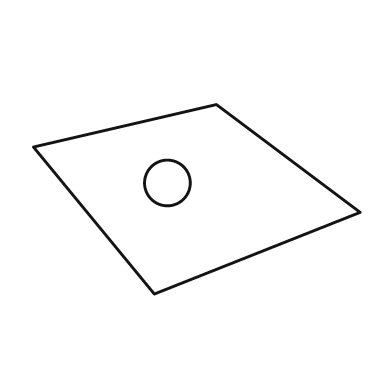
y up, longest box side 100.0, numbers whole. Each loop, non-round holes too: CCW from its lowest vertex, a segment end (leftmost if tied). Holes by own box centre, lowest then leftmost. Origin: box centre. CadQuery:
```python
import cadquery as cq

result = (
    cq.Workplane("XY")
    .moveTo(-13.0, -29.0)
    .lineTo(50.0, -4.0)
    .lineTo(6.0, 29.0)
    .lineTo(-50.0, 16.0)
    .close()
    .moveTo(-9.0, 5.0)
    .circle(7.0)
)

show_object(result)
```